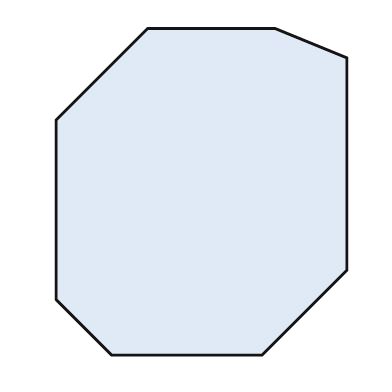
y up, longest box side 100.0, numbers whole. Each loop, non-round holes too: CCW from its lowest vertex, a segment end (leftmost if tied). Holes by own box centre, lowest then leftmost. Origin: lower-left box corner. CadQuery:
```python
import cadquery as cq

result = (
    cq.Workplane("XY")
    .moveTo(17.0, 0.0)
    .lineTo(63.0, 0.0)
    .lineTo(89.0, 26.0)
    .lineTo(89.0, 91.0)
    .lineTo(67.0, 100.0)
    .lineTo(28.0, 100.0)
    .lineTo(0.0, 72.0)
    .lineTo(0.0, 17.0)
    .close()
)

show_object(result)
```